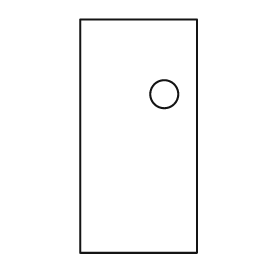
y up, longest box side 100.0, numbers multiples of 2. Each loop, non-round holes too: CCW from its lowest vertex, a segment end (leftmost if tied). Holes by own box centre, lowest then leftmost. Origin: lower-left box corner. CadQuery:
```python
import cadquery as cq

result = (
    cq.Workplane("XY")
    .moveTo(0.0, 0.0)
    .lineTo(50.0, 0.0)
    .lineTo(50.0, 100.0)
    .lineTo(0.0, 100.0)
    .close()
    .moveTo(36.0, 68.0)
    .circle(6.0)
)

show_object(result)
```